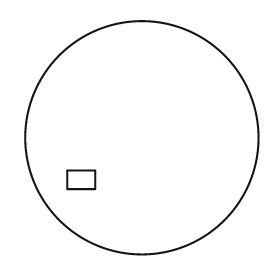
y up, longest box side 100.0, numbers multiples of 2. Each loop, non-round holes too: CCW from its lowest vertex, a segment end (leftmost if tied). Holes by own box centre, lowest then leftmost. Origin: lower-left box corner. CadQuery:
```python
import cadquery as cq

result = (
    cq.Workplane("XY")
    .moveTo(50.0, 50.0)
    .circle(50.0)
    .moveTo(18.0, 28.0)
    .lineTo(30.0, 28.0)
    .lineTo(30.0, 36.0)
    .lineTo(18.0, 36.0)
    .close()
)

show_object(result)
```